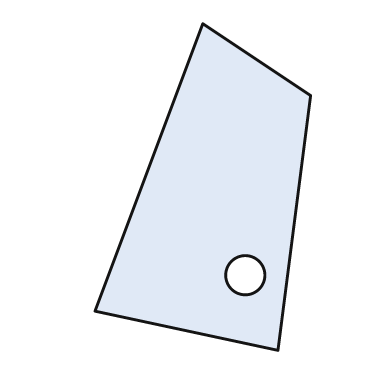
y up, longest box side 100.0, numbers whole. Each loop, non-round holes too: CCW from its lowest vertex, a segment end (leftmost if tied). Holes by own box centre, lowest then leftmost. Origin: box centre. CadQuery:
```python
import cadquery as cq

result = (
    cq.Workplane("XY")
    .moveTo(23.0, -50.0)
    .lineTo(33.0, 28.0)
    .lineTo(0.0, 50.0)
    .lineTo(-33.0, -38.0)
    .close()
    .moveTo(13.0, -27.0)
    .circle(6.0)
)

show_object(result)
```